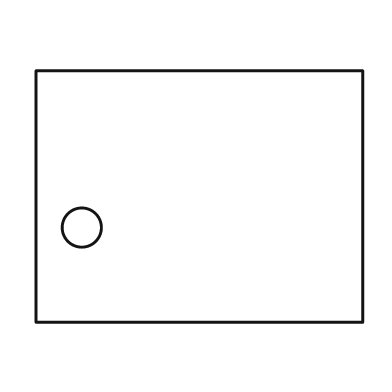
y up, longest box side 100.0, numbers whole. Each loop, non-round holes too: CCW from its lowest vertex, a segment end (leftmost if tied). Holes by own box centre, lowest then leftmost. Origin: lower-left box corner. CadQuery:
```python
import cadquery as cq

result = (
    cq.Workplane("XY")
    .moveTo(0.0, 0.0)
    .lineTo(100.0, 0.0)
    .lineTo(100.0, 77.0)
    .lineTo(0.0, 77.0)
    .close()
    .moveTo(14.0, 29.0)
    .circle(6.0)
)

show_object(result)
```